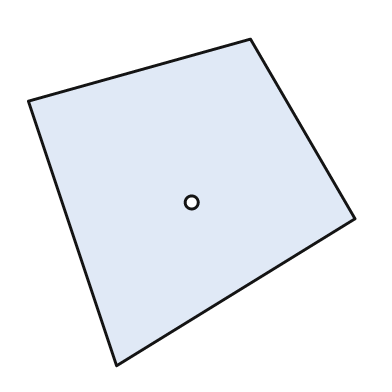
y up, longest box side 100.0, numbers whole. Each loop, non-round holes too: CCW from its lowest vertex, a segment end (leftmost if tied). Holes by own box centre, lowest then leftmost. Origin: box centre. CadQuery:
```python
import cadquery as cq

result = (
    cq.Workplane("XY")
    .moveTo(-23.0, -50.0)
    .lineTo(50.0, -5.0)
    .lineTo(18.0, 50.0)
    .lineTo(-50.0, 31.0)
    .close()
    .moveTo(0.0, 0.0)
    .circle(2.0)
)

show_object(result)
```